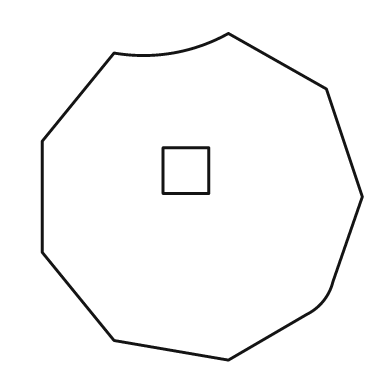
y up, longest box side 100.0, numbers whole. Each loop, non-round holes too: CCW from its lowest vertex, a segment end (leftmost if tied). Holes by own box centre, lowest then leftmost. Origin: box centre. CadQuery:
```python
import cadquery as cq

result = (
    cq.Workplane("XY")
    .moveTo(8.0, -50.0)
    .lineTo(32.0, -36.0)
    .threePointArc((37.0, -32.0), (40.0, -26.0))
    .lineTo(49.0, 0.0)
    .lineTo(38.0, 33.0)
    .lineTo(8.0, 50.0)
    .threePointArc((-9.0, 44.0), (-27.0, 44.0))
    .lineTo(-49.0, 17.0)
    .lineTo(-49.0, -17.0)
    .lineTo(-27.0, -44.0)
    .close()
    .moveTo(-12.0, 1.0)
    .lineTo(2.0, 1.0)
    .lineTo(2.0, 15.0)
    .lineTo(-12.0, 15.0)
    .close()
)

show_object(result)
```